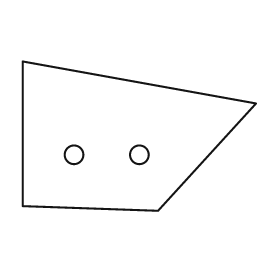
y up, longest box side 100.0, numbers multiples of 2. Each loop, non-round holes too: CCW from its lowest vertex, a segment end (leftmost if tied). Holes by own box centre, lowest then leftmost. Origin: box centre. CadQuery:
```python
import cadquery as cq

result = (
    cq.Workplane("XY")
    .moveTo(8.0, -32.0)
    .lineTo(50.0, 14.0)
    .lineTo(-50.0, 32.0)
    .lineTo(-50.0, -30.0)
    .close()
    .moveTo(-28.0, -8.0)
    .circle(4.0)
    .moveTo(0.0, -8.0)
    .circle(4.0)
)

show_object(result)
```